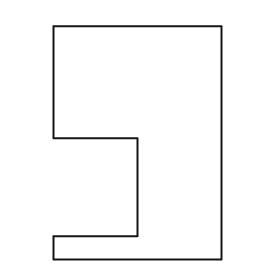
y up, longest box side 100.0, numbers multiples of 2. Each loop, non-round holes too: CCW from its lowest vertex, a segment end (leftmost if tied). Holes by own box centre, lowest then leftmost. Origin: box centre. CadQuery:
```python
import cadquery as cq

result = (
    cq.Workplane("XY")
    .moveTo(-36.0, -50.0)
    .lineTo(36.0, -50.0)
    .lineTo(36.0, 50.0)
    .lineTo(-36.0, 50.0)
    .lineTo(-36.0, 2.0)
    .lineTo(0.0, 2.0)
    .lineTo(0.0, -40.0)
    .lineTo(-36.0, -40.0)
    .close()
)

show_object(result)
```